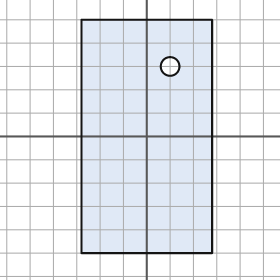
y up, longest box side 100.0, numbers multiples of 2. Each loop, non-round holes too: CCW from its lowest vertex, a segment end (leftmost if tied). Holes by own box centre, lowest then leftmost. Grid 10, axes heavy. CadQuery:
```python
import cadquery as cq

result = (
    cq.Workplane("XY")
    .moveTo(-28.0, -50.0)
    .lineTo(28.0, -50.0)
    .lineTo(28.0, 50.0)
    .lineTo(-28.0, 50.0)
    .close()
    .moveTo(10.0, 30.0)
    .circle(4.0)
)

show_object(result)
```